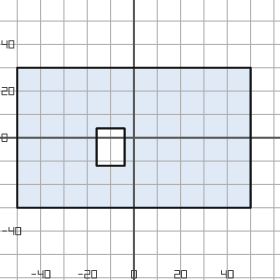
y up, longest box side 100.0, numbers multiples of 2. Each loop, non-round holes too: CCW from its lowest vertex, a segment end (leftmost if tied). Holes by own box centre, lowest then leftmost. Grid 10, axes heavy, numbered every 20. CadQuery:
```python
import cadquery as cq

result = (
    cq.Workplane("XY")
    .moveTo(-50.0, -30.0)
    .lineTo(50.0, -30.0)
    .lineTo(50.0, 30.0)
    .lineTo(-50.0, 30.0)
    .close()
    .moveTo(-16.0, -12.0)
    .lineTo(-4.0, -12.0)
    .lineTo(-4.0, 4.0)
    .lineTo(-16.0, 4.0)
    .close()
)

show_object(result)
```